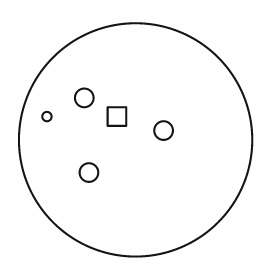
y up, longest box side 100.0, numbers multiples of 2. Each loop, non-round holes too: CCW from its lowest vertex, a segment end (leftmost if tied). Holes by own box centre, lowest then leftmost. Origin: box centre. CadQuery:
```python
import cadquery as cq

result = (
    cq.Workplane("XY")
    .moveTo(0.0, 0.0)
    .circle(50.0)
    .moveTo(-20.0, -14.0)
    .circle(4.0)
    .moveTo(12.0, 4.0)
    .circle(4.0)
    .moveTo(-38.0, 10.0)
    .circle(2.0)
    .moveTo(-12.0, 6.0)
    .lineTo(-4.0, 6.0)
    .lineTo(-4.0, 14.0)
    .lineTo(-12.0, 14.0)
    .close()
    .moveTo(-22.0, 18.0)
    .circle(4.0)
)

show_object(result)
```